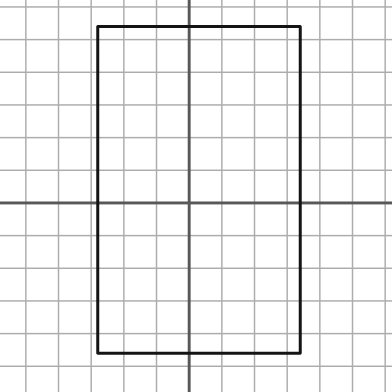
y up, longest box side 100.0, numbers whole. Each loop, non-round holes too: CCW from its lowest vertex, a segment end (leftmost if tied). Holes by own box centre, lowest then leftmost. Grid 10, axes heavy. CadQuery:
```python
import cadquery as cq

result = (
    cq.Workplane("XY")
    .moveTo(-28.0, -46.0)
    .lineTo(34.0, -46.0)
    .lineTo(34.0, 54.0)
    .lineTo(-28.0, 54.0)
    .close()
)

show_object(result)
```